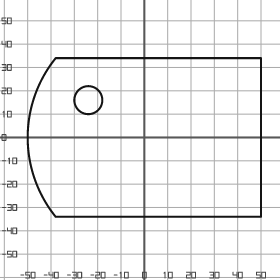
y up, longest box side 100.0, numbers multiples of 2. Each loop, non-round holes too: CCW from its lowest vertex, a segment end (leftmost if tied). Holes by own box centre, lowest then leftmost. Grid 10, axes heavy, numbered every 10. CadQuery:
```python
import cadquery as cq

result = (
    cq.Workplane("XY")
    .moveTo(-38.0, -34.0)
    .lineTo(50.0, -34.0)
    .lineTo(50.0, 34.0)
    .lineTo(-38.0, 34.0)
    .threePointArc((-50.0, 0.0), (-38.0, -34.0))
    .close()
    .moveTo(-24.0, 16.0)
    .circle(6.0)
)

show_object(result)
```